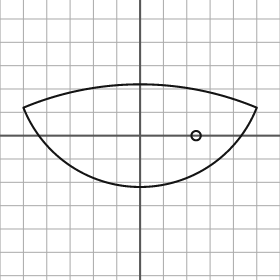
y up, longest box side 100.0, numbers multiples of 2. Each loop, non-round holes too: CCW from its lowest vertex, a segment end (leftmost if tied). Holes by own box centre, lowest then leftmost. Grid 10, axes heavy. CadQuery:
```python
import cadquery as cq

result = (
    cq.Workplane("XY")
    .moveTo(-50.0, 12.0)
    .threePointArc((0.0, -22.0), (50.0, 12.0))
    .threePointArc((0.0, 22.0), (-50.0, 12.0))
    .close()
    .moveTo(24.0, 0.0)
    .circle(2.0)
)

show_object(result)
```